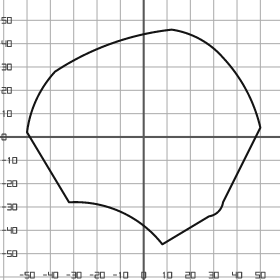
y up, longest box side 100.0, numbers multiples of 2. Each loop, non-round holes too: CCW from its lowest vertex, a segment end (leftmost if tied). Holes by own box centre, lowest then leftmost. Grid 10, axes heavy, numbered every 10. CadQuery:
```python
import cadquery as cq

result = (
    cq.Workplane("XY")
    .moveTo(8.0, -46.0)
    .lineTo(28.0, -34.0)
    .threePointArc((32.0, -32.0), (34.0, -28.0))
    .lineTo(50.0, 4.0)
    .threePointArc((44.0, 20.0), (34.0, 34.0))
    .threePointArc((24.0, 42.0), (12.0, 46.0))
    .threePointArc((-14.0, 40.0), (-38.0, 28.0))
    .threePointArc((-46.0, 16.0), (-50.0, 2.0))
    .lineTo(-32.0, -28.0)
    .threePointArc((-10.0, -32.0), (8.0, -46.0))
    .close()
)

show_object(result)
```